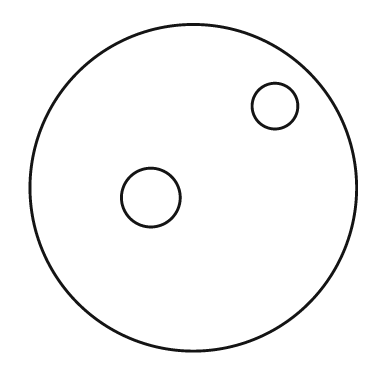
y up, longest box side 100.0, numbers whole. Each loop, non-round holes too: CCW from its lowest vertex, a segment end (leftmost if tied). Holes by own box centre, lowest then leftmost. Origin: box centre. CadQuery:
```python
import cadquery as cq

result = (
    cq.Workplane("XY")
    .moveTo(0.0, 0.0)
    .circle(50.0)
    .moveTo(-13.0, -3.0)
    .circle(9.0)
    .moveTo(25.0, 25.0)
    .circle(7.0)
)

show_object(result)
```